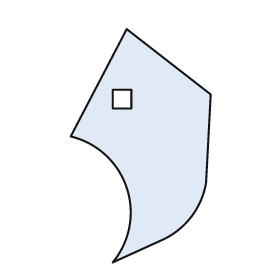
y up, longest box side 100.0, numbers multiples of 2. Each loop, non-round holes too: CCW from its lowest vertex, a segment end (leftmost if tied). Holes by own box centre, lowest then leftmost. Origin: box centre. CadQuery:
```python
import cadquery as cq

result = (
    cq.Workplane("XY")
    .moveTo(-12.0, -50.0)
    .lineTo(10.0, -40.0)
    .threePointArc((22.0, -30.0), (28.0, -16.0))
    .lineTo(30.0, 22.0)
    .lineTo(-6.0, 50.0)
    .lineTo(-30.0, 4.0)
    .threePointArc((-6.0, -18.0), (-12.0, -50.0))
    .close()
    .moveTo(-12.0, 16.0)
    .lineTo(-4.0, 16.0)
    .lineTo(-4.0, 24.0)
    .lineTo(-12.0, 24.0)
    .close()
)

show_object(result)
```